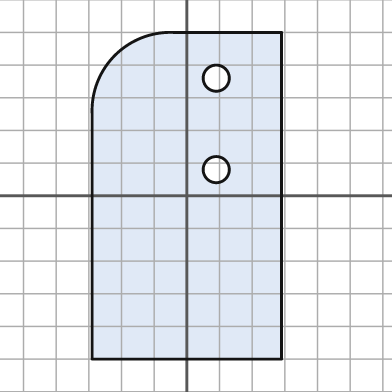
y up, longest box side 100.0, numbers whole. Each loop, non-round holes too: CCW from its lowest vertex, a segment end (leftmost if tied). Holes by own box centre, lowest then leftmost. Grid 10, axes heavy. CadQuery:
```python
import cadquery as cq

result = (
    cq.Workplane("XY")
    .moveTo(-29.0, -50.0)
    .lineTo(29.0, -50.0)
    .lineTo(29.0, 50.0)
    .lineTo(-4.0, 50.0)
    .threePointArc((-22.0, 43.0), (-29.0, 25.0))
    .close()
    .moveTo(9.0, 8.0)
    .circle(4.0)
    .moveTo(9.0, 36.0)
    .circle(4.0)
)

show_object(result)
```